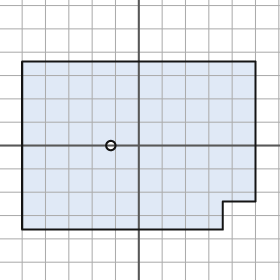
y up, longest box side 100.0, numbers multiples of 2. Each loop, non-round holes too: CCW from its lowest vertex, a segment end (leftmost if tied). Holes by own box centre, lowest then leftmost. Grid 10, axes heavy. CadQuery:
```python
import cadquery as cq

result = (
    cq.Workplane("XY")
    .moveTo(-50.0, -36.0)
    .lineTo(36.0, -36.0)
    .lineTo(36.0, -24.0)
    .lineTo(50.0, -24.0)
    .lineTo(50.0, 36.0)
    .lineTo(-50.0, 36.0)
    .close()
    .moveTo(-12.0, 0.0)
    .circle(2.0)
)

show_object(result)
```